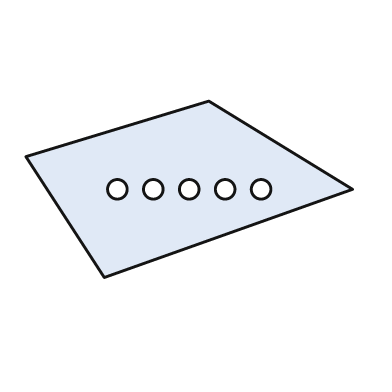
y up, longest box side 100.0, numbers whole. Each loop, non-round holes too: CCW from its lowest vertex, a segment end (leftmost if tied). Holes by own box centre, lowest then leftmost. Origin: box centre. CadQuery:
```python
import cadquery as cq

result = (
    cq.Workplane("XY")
    .moveTo(-26.0, -27.0)
    .lineTo(50.0, 0.0)
    .lineTo(6.0, 27.0)
    .lineTo(-50.0, 10.0)
    .close()
    .moveTo(-22.0, 0.0)
    .circle(3.0)
    .moveTo(-11.0, 0.0)
    .circle(3.0)
    .moveTo(0.0, 0.0)
    .circle(3.0)
    .moveTo(11.0, 0.0)
    .circle(3.0)
    .moveTo(22.0, 0.0)
    .circle(3.0)
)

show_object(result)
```